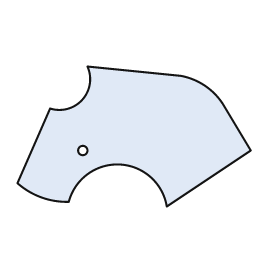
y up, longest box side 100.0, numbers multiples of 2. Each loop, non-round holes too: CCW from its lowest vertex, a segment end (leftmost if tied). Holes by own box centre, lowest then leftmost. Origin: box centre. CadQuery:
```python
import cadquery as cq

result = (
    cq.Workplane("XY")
    .moveTo(14.0, -30.0)
    .lineTo(50.0, -6.0)
    .lineTo(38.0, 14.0)
    .threePointArc((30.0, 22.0), (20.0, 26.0))
    .lineTo(-20.0, 30.0)
    .threePointArc((-22.0, 16.0), (-36.0, 12.0))
    .lineTo(-50.0, -20.0)
    .threePointArc((-40.0, -26.0), (-28.0, -28.0))
    .threePointArc((-6.0, -12.0), (14.0, -30.0))
    .close()
    .moveTo(-22.0, -6.0)
    .circle(2.0)
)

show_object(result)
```